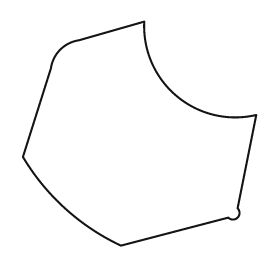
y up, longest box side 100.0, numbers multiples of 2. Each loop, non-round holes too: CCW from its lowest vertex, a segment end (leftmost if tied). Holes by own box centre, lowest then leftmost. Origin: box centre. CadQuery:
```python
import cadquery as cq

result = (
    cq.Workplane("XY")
    .moveTo(-8.0, -48.0)
    .lineTo(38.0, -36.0)
    .threePointArc((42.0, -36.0), (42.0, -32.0))
    .lineTo(50.0, 8.0)
    .threePointArc((16.0, 16.0), (2.0, 48.0))
    .lineTo(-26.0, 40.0)
    .threePointArc((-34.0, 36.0), (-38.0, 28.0))
    .lineTo(-50.0, -10.0)
    .threePointArc((-32.0, -32.0), (-8.0, -48.0))
    .close()
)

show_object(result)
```